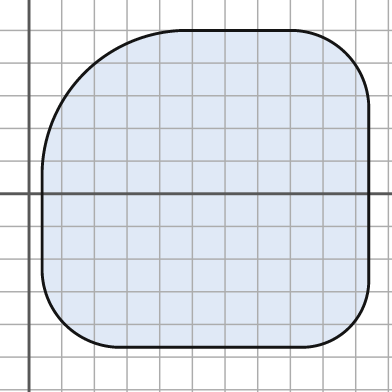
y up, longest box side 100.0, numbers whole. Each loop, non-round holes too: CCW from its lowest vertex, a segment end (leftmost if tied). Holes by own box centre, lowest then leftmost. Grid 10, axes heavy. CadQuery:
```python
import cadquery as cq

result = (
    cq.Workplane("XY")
    .moveTo(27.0, -47.0)
    .lineTo(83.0, -47.0)
    .threePointArc((98.0, -41.0), (104.0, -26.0))
    .lineTo(104.0, 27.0)
    .threePointArc((97.0, 43.0), (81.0, 50.0))
    .lineTo(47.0, 50.0)
    .threePointArc((17.0, 37.0), (4.0, 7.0))
    .lineTo(4.0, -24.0)
    .threePointArc((11.0, -40.0), (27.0, -47.0))
    .close()
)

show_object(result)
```